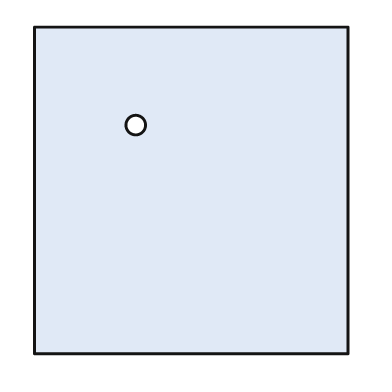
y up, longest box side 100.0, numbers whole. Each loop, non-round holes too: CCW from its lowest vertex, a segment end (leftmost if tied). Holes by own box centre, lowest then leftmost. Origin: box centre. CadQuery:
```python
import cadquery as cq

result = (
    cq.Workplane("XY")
    .moveTo(-48.0, -50.0)
    .lineTo(48.0, -50.0)
    .lineTo(48.0, 50.0)
    .lineTo(-48.0, 50.0)
    .close()
    .moveTo(-17.0, 20.0)
    .circle(3.0)
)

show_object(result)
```